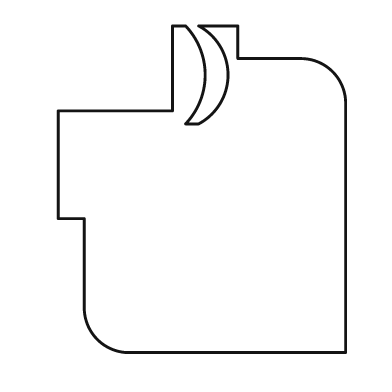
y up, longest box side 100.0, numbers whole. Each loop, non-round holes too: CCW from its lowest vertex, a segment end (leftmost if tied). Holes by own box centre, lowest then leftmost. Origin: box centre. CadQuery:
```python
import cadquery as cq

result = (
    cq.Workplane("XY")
    .moveTo(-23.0, -50.0)
    .lineTo(44.0, -50.0)
    .lineTo(44.0, 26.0)
    .threePointArc((40.0, 36.0), (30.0, 40.0))
    .lineTo(11.0, 40.0)
    .lineTo(11.0, 50.0)
    .lineTo(-1.0, 50.0)
    .threePointArc((8.0, 35.0), (-1.0, 20.0))
    .lineTo(-5.0, 20.0)
    .threePointArc((1.0, 35.0), (-5.0, 50.0))
    .lineTo(-9.0, 50.0)
    .lineTo(-9.0, 24.0)
    .lineTo(-44.0, 24.0)
    .lineTo(-44.0, -9.0)
    .lineTo(-36.0, -9.0)
    .lineTo(-36.0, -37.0)
    .threePointArc((-32.0, -46.0), (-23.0, -50.0))
    .close()
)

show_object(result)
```